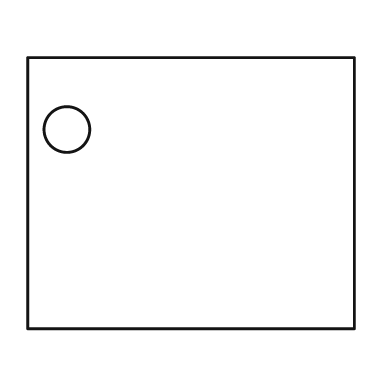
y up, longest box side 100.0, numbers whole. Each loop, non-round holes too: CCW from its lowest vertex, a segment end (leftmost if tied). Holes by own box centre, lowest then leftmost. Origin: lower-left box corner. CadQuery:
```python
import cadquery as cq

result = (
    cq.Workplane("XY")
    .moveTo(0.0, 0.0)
    .lineTo(100.0, 0.0)
    .lineTo(100.0, 83.0)
    .lineTo(0.0, 83.0)
    .close()
    .moveTo(12.0, 61.0)
    .circle(7.0)
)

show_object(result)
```